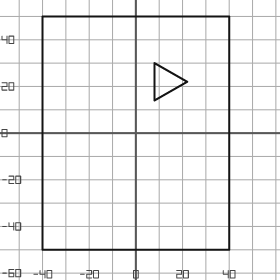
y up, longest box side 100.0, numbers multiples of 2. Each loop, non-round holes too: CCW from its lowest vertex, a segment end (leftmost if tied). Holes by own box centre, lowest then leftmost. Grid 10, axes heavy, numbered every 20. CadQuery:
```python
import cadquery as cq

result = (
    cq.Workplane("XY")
    .moveTo(-40.0, -50.0)
    .lineTo(40.0, -50.0)
    .lineTo(40.0, 50.0)
    .lineTo(-40.0, 50.0)
    .close()
    .moveTo(8.0, 14.0)
    .lineTo(22.0, 22.0)
    .lineTo(8.0, 30.0)
    .close()
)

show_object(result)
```